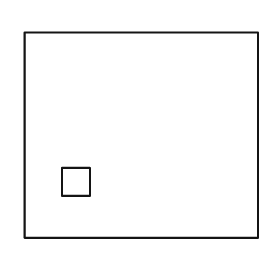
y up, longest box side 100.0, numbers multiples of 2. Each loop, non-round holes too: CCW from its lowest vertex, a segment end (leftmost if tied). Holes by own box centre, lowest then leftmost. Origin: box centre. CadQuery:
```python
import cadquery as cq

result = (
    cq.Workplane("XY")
    .moveTo(-50.0, -44.0)
    .lineTo(50.0, -44.0)
    .lineTo(50.0, 44.0)
    .lineTo(-50.0, 44.0)
    .close()
    .moveTo(-34.0, -26.0)
    .lineTo(-22.0, -26.0)
    .lineTo(-22.0, -14.0)
    .lineTo(-34.0, -14.0)
    .close()
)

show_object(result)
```